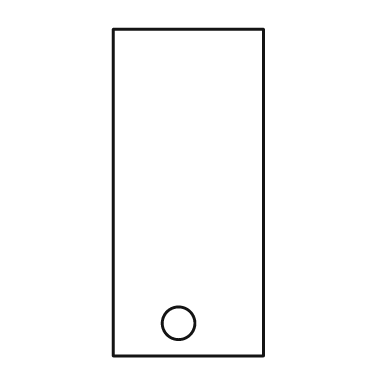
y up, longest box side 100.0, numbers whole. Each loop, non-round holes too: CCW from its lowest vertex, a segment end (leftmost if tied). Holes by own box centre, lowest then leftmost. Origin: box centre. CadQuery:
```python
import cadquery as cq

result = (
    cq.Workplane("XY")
    .moveTo(-23.0, -50.0)
    .lineTo(23.0, -50.0)
    .lineTo(23.0, 50.0)
    .lineTo(-23.0, 50.0)
    .close()
    .moveTo(-3.0, -40.0)
    .circle(5.0)
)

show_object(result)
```